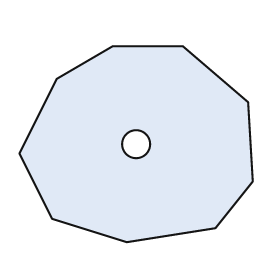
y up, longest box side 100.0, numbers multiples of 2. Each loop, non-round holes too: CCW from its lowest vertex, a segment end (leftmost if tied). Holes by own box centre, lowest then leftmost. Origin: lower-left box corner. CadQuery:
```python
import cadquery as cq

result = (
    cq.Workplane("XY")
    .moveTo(46.0, 0.0)
    .lineTo(84.0, 6.0)
    .lineTo(100.0, 26.0)
    .lineTo(98.0, 60.0)
    .lineTo(70.0, 84.0)
    .lineTo(40.0, 84.0)
    .lineTo(16.0, 70.0)
    .lineTo(0.0, 38.0)
    .lineTo(14.0, 10.0)
    .close()
    .moveTo(50.0, 42.0)
    .circle(6.0)
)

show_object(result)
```